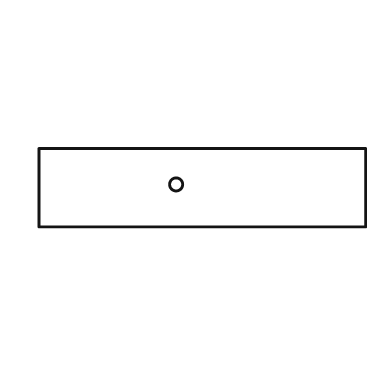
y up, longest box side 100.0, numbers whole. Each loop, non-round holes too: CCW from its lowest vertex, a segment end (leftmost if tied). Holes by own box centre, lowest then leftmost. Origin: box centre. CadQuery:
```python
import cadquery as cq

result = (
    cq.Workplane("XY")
    .moveTo(-50.0, -12.0)
    .lineTo(50.0, -12.0)
    .lineTo(50.0, 12.0)
    .lineTo(-50.0, 12.0)
    .close()
    .moveTo(-8.0, 1.0)
    .circle(2.0)
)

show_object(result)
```